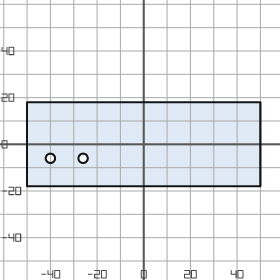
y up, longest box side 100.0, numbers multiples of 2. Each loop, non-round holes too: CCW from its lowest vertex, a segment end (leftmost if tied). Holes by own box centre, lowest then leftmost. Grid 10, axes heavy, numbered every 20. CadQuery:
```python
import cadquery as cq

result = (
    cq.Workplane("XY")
    .moveTo(-50.0, -18.0)
    .lineTo(50.0, -18.0)
    .lineTo(50.0, 18.0)
    .lineTo(-50.0, 18.0)
    .close()
    .moveTo(-40.0, -6.0)
    .circle(2.0)
    .moveTo(-26.0, -6.0)
    .circle(2.0)
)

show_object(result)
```